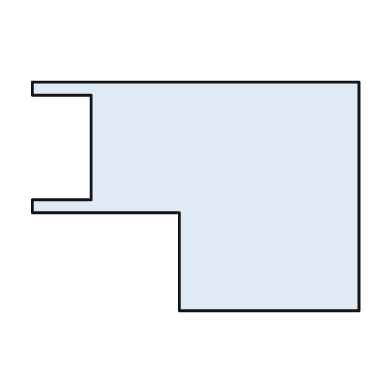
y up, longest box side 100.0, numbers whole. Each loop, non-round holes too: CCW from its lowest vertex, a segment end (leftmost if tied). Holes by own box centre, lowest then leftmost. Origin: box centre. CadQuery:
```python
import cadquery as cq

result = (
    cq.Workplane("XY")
    .moveTo(-5.0, -35.0)
    .lineTo(50.0, -35.0)
    .lineTo(50.0, 35.0)
    .lineTo(-50.0, 35.0)
    .lineTo(-50.0, 31.0)
    .lineTo(-32.0, 31.0)
    .lineTo(-32.0, -1.0)
    .lineTo(-50.0, -1.0)
    .lineTo(-50.0, -5.0)
    .lineTo(-5.0, -5.0)
    .close()
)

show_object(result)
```